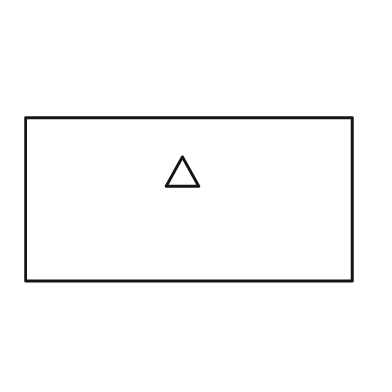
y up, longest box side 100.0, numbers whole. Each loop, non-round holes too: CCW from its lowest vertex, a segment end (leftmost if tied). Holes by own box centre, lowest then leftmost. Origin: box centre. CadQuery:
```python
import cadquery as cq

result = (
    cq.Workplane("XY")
    .moveTo(-50.0, -25.0)
    .lineTo(50.0, -25.0)
    .lineTo(50.0, 25.0)
    .lineTo(-50.0, 25.0)
    .close()
    .moveTo(-7.0, 4.0)
    .lineTo(3.0, 4.0)
    .lineTo(-2.0, 13.0)
    .close()
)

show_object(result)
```